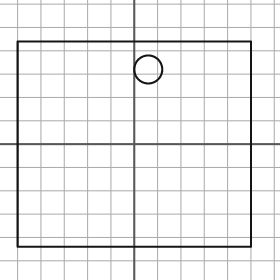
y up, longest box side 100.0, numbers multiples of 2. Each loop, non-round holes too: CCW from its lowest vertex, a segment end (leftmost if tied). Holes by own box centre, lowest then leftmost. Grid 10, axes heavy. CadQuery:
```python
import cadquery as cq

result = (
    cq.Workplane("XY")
    .moveTo(-50.0, -44.0)
    .lineTo(50.0, -44.0)
    .lineTo(50.0, 44.0)
    .lineTo(-50.0, 44.0)
    .close()
    .moveTo(6.0, 32.0)
    .circle(6.0)
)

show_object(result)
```